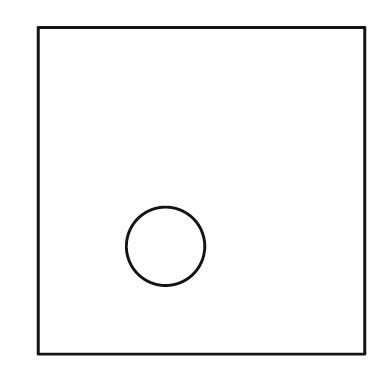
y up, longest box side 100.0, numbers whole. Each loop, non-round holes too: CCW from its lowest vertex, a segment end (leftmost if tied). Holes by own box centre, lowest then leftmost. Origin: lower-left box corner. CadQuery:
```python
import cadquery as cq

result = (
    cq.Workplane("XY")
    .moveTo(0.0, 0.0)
    .lineTo(100.0, 0.0)
    .lineTo(100.0, 100.0)
    .lineTo(0.0, 100.0)
    .close()
    .moveTo(39.0, 33.0)
    .circle(12.0)
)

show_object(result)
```